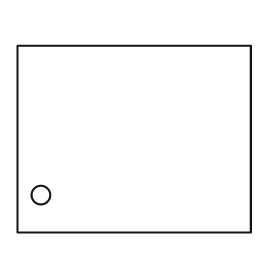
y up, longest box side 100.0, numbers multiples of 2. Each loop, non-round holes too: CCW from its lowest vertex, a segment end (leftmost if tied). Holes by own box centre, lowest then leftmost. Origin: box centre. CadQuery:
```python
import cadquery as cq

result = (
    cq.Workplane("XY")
    .moveTo(-50.0, -40.0)
    .lineTo(50.0, -40.0)
    .lineTo(50.0, 40.0)
    .lineTo(-50.0, 40.0)
    .close()
    .moveTo(-40.0, -24.0)
    .circle(4.0)
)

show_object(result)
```